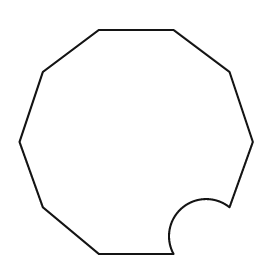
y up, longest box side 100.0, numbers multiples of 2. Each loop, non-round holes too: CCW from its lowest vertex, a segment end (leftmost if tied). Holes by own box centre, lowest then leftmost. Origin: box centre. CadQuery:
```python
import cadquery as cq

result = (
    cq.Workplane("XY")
    .moveTo(-16.0, -48.0)
    .lineTo(16.0, -48.0)
    .threePointArc((20.0, -28.0), (40.0, -28.0))
    .lineTo(50.0, 0.0)
    .lineTo(40.0, 30.0)
    .lineTo(16.0, 48.0)
    .lineTo(-16.0, 48.0)
    .lineTo(-40.0, 30.0)
    .lineTo(-50.0, 0.0)
    .lineTo(-40.0, -28.0)
    .close()
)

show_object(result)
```